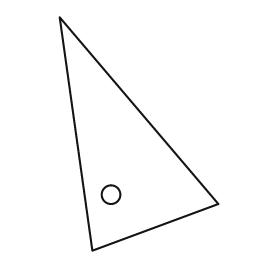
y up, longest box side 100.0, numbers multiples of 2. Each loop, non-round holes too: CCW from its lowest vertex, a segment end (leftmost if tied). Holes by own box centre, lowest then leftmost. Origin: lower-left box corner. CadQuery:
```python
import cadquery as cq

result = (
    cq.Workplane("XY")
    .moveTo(14.0, 0.0)
    .lineTo(68.0, 20.0)
    .lineTo(0.0, 100.0)
    .close()
    .moveTo(22.0, 24.0)
    .circle(4.0)
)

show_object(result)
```